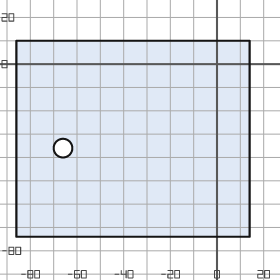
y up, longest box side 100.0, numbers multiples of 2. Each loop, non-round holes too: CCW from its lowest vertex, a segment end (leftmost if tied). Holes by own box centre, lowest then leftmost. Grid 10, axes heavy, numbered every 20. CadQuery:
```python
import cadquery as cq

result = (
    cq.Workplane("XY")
    .moveTo(-86.0, -74.0)
    .lineTo(14.0, -74.0)
    .lineTo(14.0, 10.0)
    .lineTo(-86.0, 10.0)
    .close()
    .moveTo(-66.0, -36.0)
    .circle(4.0)
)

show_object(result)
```